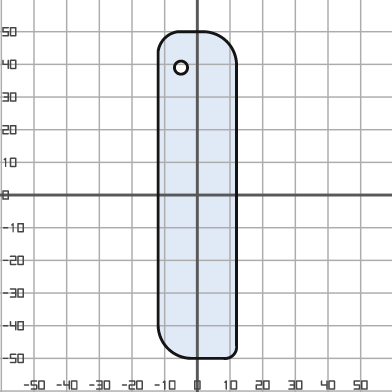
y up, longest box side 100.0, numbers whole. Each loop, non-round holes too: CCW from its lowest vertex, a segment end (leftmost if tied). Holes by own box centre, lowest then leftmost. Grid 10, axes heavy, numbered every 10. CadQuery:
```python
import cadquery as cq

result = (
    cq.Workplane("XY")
    .moveTo(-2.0, -50.0)
    .lineTo(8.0, -50.0)
    .threePointArc((11.0, -49.0), (12.0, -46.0))
    .lineTo(12.0, 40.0)
    .threePointArc((9.0, 47.0), (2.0, 50.0))
    .lineTo(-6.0, 50.0)
    .threePointArc((-10.0, 48.0), (-12.0, 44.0))
    .lineTo(-12.0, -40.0)
    .threePointArc((-9.0, -47.0), (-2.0, -50.0))
    .close()
    .moveTo(-5.0, 39.0)
    .circle(2.0)
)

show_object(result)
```